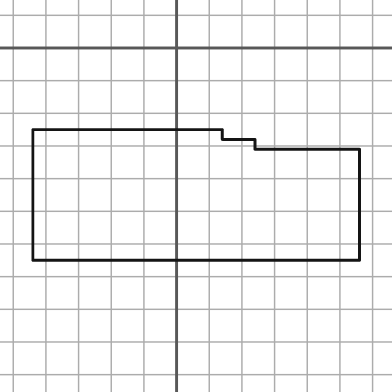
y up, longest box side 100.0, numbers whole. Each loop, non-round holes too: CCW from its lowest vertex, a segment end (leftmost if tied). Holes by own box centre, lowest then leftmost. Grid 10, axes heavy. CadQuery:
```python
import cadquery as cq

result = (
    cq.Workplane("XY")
    .moveTo(-44.0, -65.0)
    .lineTo(56.0, -65.0)
    .lineTo(56.0, -31.0)
    .lineTo(24.0, -31.0)
    .lineTo(24.0, -28.0)
    .lineTo(14.0, -28.0)
    .lineTo(14.0, -25.0)
    .lineTo(-44.0, -25.0)
    .close()
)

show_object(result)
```